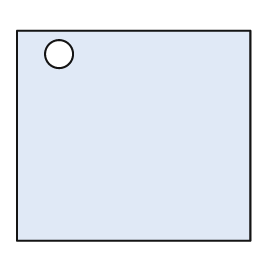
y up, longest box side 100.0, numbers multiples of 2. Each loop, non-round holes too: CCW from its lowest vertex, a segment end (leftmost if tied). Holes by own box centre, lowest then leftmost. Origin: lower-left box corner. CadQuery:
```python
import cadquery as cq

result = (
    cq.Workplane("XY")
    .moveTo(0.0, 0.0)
    .lineTo(100.0, 0.0)
    .lineTo(100.0, 90.0)
    .lineTo(0.0, 90.0)
    .close()
    .moveTo(18.0, 80.0)
    .circle(6.0)
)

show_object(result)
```